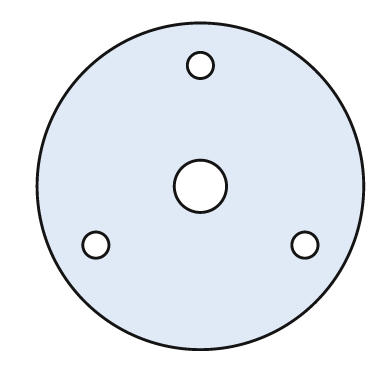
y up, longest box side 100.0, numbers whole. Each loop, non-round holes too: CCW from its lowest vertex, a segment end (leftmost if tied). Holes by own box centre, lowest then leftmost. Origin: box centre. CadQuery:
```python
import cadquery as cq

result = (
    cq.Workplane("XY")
    .moveTo(0.0, 0.0)
    .circle(50.0)
    .moveTo(-32.0, -18.0)
    .circle(4.0)
    .moveTo(32.0, -18.0)
    .circle(4.0)
    .moveTo(0.0, 0.0)
    .circle(8.0)
    .moveTo(0.0, 37.0)
    .circle(4.0)
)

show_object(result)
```